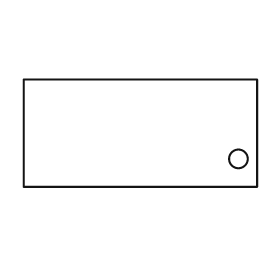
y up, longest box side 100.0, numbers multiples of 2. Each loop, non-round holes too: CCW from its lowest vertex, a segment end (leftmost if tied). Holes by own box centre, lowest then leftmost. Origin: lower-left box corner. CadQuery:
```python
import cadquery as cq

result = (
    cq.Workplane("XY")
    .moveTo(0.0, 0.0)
    .lineTo(100.0, 0.0)
    .lineTo(100.0, 46.0)
    .lineTo(0.0, 46.0)
    .close()
    .moveTo(92.0, 12.0)
    .circle(4.0)
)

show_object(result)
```